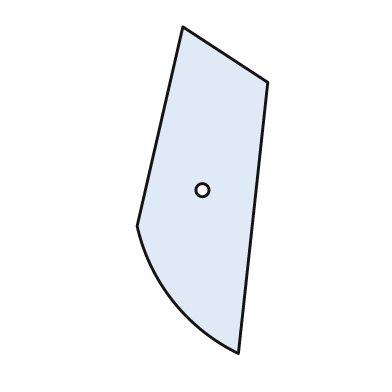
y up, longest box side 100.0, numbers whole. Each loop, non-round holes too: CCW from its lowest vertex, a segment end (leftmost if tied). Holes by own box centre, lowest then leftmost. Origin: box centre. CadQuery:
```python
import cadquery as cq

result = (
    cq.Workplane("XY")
    .moveTo(11.0, -50.0)
    .lineTo(20.0, 33.0)
    .lineTo(-6.0, 50.0)
    .lineTo(-20.0, -11.0)
    .threePointArc((-9.0, -34.0), (11.0, -50.0))
    .close()
    .moveTo(0.0, 0.0)
    .circle(2.0)
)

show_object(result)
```